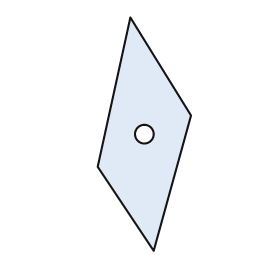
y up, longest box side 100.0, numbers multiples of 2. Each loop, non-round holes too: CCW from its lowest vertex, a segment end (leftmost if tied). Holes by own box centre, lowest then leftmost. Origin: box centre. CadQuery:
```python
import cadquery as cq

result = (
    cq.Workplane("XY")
    .moveTo(4.0, -50.0)
    .lineTo(20.0, 8.0)
    .lineTo(-6.0, 50.0)
    .lineTo(-20.0, -14.0)
    .close()
    .moveTo(0.0, 0.0)
    .circle(4.0)
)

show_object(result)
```